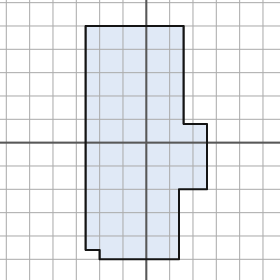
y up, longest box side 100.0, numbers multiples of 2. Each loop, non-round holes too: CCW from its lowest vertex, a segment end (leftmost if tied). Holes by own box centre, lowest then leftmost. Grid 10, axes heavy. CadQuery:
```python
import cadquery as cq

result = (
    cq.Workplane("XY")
    .moveTo(-20.0, -50.0)
    .lineTo(14.0, -50.0)
    .lineTo(14.0, -20.0)
    .lineTo(26.0, -20.0)
    .lineTo(26.0, 8.0)
    .lineTo(16.0, 8.0)
    .lineTo(16.0, 50.0)
    .lineTo(-26.0, 50.0)
    .lineTo(-26.0, -46.0)
    .lineTo(-20.0, -46.0)
    .close()
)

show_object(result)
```